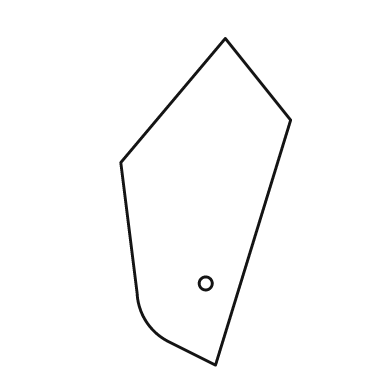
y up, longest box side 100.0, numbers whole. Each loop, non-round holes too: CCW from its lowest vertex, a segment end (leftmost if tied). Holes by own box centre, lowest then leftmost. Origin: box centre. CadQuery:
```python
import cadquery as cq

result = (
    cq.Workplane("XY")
    .moveTo(3.0, -50.0)
    .lineTo(26.0, 25.0)
    .lineTo(6.0, 50.0)
    .lineTo(-26.0, 12.0)
    .lineTo(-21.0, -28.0)
    .threePointArc((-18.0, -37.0), (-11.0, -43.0))
    .close()
    .moveTo(0.0, -25.0)
    .circle(2.0)
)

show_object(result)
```